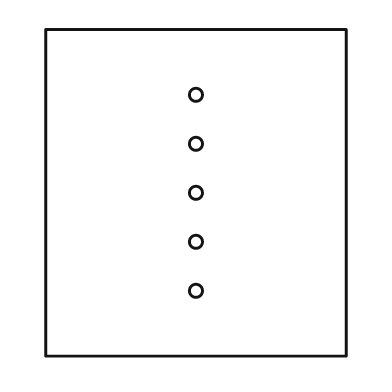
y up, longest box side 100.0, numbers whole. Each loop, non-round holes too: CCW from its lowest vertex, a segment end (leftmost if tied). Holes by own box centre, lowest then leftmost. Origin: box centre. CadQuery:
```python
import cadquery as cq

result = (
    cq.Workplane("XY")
    .moveTo(-46.0, -50.0)
    .lineTo(46.0, -50.0)
    .lineTo(46.0, 50.0)
    .lineTo(-46.0, 50.0)
    .close()
    .moveTo(0.0, -30.0)
    .circle(2.0)
    .moveTo(0.0, -15.0)
    .circle(2.0)
    .moveTo(0.0, 0.0)
    .circle(2.0)
    .moveTo(0.0, 15.0)
    .circle(2.0)
    .moveTo(0.0, 30.0)
    .circle(2.0)
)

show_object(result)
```